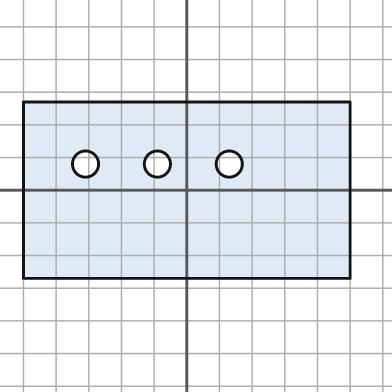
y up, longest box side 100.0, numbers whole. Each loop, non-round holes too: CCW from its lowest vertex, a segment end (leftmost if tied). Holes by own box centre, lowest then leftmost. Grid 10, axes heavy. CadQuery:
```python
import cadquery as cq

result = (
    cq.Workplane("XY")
    .moveTo(-50.0, -27.0)
    .lineTo(50.0, -27.0)
    .lineTo(50.0, 27.0)
    .lineTo(-50.0, 27.0)
    .close()
    .moveTo(-31.0, 8.0)
    .circle(4.0)
    .moveTo(-9.0, 8.0)
    .circle(4.0)
    .moveTo(13.0, 8.0)
    .circle(4.0)
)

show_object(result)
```